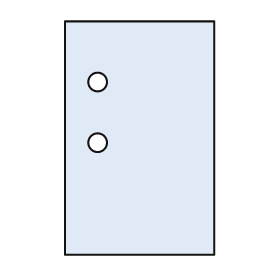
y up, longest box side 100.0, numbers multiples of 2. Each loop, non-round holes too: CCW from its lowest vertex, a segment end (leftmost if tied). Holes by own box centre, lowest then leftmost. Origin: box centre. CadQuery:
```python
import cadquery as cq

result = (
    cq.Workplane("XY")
    .moveTo(-32.0, -50.0)
    .lineTo(32.0, -50.0)
    .lineTo(32.0, 50.0)
    .lineTo(-32.0, 50.0)
    .close()
    .moveTo(-18.0, -2.0)
    .circle(4.0)
    .moveTo(-18.0, 24.0)
    .circle(4.0)
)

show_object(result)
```